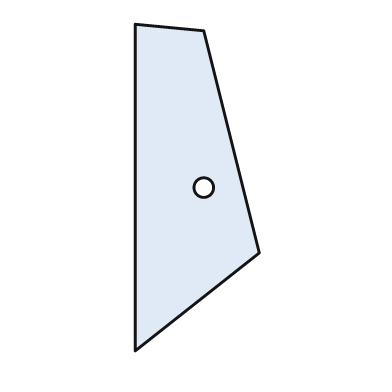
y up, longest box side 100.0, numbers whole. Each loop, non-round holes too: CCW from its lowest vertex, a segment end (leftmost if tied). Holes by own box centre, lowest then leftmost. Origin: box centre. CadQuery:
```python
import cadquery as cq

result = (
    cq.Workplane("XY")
    .moveTo(-19.0, -50.0)
    .lineTo(19.0, -20.0)
    .lineTo(2.0, 48.0)
    .lineTo(-19.0, 50.0)
    .close()
    .moveTo(2.0, 0.0)
    .circle(3.0)
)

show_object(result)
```